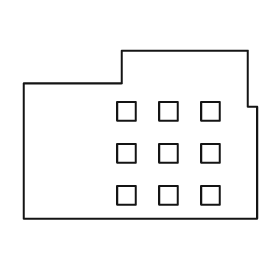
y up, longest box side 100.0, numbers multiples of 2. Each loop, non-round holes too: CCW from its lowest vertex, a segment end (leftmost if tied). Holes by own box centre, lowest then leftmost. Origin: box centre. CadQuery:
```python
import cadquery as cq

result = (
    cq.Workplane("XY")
    .moveTo(-50.0, -36.0)
    .lineTo(50.0, -36.0)
    .lineTo(50.0, 12.0)
    .lineTo(46.0, 12.0)
    .lineTo(46.0, 36.0)
    .lineTo(-8.0, 36.0)
    .lineTo(-8.0, 22.0)
    .lineTo(-50.0, 22.0)
    .close()
    .moveTo(-10.0, -30.0)
    .lineTo(-2.0, -30.0)
    .lineTo(-2.0, -22.0)
    .lineTo(-10.0, -22.0)
    .close()
    .moveTo(8.0, -30.0)
    .lineTo(16.0, -30.0)
    .lineTo(16.0, -22.0)
    .lineTo(8.0, -22.0)
    .close()
    .moveTo(26.0, -30.0)
    .lineTo(34.0, -30.0)
    .lineTo(34.0, -22.0)
    .lineTo(26.0, -22.0)
    .close()
    .moveTo(-10.0, -12.0)
    .lineTo(-2.0, -12.0)
    .lineTo(-2.0, -4.0)
    .lineTo(-10.0, -4.0)
    .close()
    .moveTo(8.0, -12.0)
    .lineTo(16.0, -12.0)
    .lineTo(16.0, -4.0)
    .lineTo(8.0, -4.0)
    .close()
    .moveTo(26.0, -12.0)
    .lineTo(34.0, -12.0)
    .lineTo(34.0, -4.0)
    .lineTo(26.0, -4.0)
    .close()
    .moveTo(-10.0, 6.0)
    .lineTo(-2.0, 6.0)
    .lineTo(-2.0, 14.0)
    .lineTo(-10.0, 14.0)
    .close()
    .moveTo(8.0, 6.0)
    .lineTo(16.0, 6.0)
    .lineTo(16.0, 14.0)
    .lineTo(8.0, 14.0)
    .close()
    .moveTo(26.0, 6.0)
    .lineTo(34.0, 6.0)
    .lineTo(34.0, 14.0)
    .lineTo(26.0, 14.0)
    .close()
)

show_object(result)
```